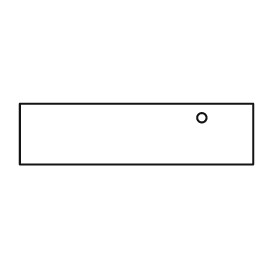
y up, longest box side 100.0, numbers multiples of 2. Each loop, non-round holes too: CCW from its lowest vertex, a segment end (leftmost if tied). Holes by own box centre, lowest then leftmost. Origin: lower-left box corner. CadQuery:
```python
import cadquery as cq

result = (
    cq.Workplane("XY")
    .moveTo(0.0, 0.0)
    .lineTo(100.0, 0.0)
    .lineTo(100.0, 26.0)
    .lineTo(0.0, 26.0)
    .close()
    .moveTo(78.0, 20.0)
    .circle(2.0)
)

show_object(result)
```